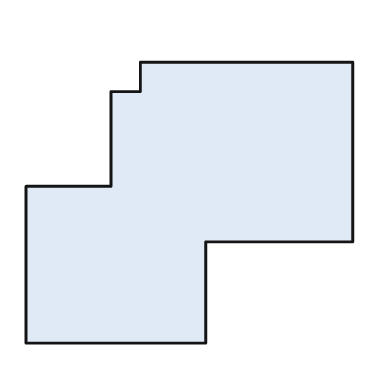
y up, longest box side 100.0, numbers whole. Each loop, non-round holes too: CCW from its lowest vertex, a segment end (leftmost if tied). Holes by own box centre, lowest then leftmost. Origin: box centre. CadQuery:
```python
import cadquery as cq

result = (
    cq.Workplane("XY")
    .moveTo(-50.0, -43.0)
    .lineTo(5.0, -43.0)
    .lineTo(5.0, -12.0)
    .lineTo(50.0, -12.0)
    .lineTo(50.0, 43.0)
    .lineTo(-15.0, 43.0)
    .lineTo(-15.0, 34.0)
    .lineTo(-24.0, 34.0)
    .lineTo(-24.0, 5.0)
    .lineTo(-50.0, 5.0)
    .close()
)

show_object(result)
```